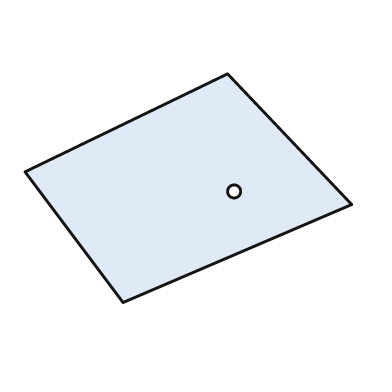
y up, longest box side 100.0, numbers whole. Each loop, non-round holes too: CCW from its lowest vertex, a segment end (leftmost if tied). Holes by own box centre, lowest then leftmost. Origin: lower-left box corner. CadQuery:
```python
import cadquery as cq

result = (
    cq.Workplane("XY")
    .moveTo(30.0, 0.0)
    .lineTo(100.0, 30.0)
    .lineTo(62.0, 70.0)
    .lineTo(0.0, 40.0)
    .close()
    .moveTo(64.0, 34.0)
    .circle(2.0)
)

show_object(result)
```